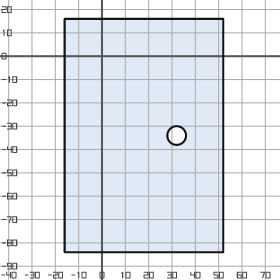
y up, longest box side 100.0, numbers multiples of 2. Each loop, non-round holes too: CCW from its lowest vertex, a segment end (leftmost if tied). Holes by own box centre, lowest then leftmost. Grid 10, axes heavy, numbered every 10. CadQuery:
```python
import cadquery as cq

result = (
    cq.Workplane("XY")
    .moveTo(-16.0, -84.0)
    .lineTo(52.0, -84.0)
    .lineTo(52.0, 16.0)
    .lineTo(-16.0, 16.0)
    .close()
    .moveTo(32.0, -34.0)
    .circle(4.0)
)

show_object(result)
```